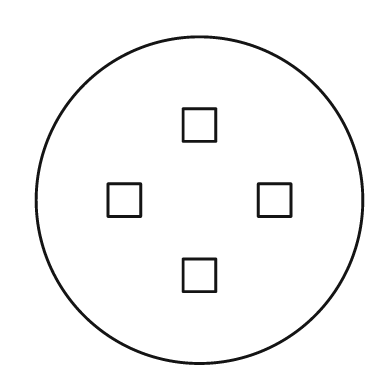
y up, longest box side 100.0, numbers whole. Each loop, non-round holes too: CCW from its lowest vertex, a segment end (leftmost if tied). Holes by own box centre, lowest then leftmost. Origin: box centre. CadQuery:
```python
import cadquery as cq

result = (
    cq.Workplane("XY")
    .moveTo(0.0, 0.0)
    .circle(50.0)
    .moveTo(-5.0, -28.0)
    .lineTo(5.0, -28.0)
    .lineTo(5.0, -18.0)
    .lineTo(-5.0, -18.0)
    .close()
    .moveTo(-28.0, -5.0)
    .lineTo(-18.0, -5.0)
    .lineTo(-18.0, 5.0)
    .lineTo(-28.0, 5.0)
    .close()
    .moveTo(18.0, -5.0)
    .lineTo(28.0, -5.0)
    .lineTo(28.0, 5.0)
    .lineTo(18.0, 5.0)
    .close()
    .moveTo(-5.0, 18.0)
    .lineTo(5.0, 18.0)
    .lineTo(5.0, 28.0)
    .lineTo(-5.0, 28.0)
    .close()
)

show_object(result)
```